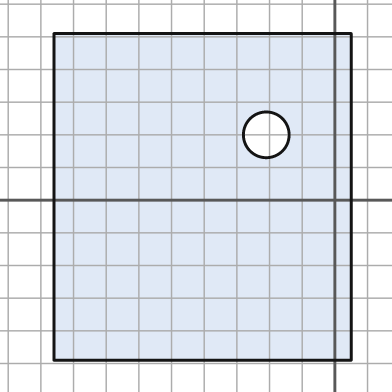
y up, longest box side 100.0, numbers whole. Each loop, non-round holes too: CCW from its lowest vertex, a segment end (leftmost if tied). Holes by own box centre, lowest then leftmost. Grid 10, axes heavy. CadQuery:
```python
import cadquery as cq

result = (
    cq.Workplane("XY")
    .moveTo(-86.0, -49.0)
    .lineTo(5.0, -49.0)
    .lineTo(5.0, 51.0)
    .lineTo(-86.0, 51.0)
    .close()
    .moveTo(-21.0, 20.0)
    .circle(7.0)
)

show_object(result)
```